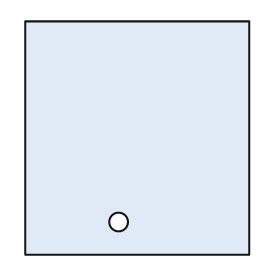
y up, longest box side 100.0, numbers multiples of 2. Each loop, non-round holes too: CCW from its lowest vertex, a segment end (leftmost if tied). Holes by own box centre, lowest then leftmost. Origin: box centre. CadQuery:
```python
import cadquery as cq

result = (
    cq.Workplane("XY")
    .moveTo(-48.0, -50.0)
    .lineTo(48.0, -50.0)
    .lineTo(48.0, 50.0)
    .lineTo(-48.0, 50.0)
    .close()
    .moveTo(-8.0, -36.0)
    .circle(4.0)
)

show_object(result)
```